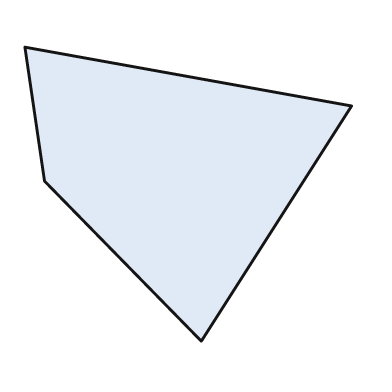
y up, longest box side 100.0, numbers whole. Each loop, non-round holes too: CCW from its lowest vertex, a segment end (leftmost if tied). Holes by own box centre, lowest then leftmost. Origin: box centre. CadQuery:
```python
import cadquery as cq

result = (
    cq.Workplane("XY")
    .moveTo(4.0, -45.0)
    .lineTo(50.0, 27.0)
    .lineTo(-50.0, 45.0)
    .lineTo(-44.0, 4.0)
    .close()
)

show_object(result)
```